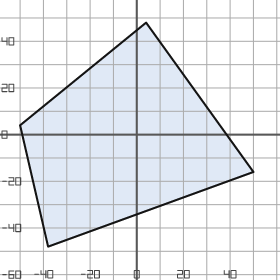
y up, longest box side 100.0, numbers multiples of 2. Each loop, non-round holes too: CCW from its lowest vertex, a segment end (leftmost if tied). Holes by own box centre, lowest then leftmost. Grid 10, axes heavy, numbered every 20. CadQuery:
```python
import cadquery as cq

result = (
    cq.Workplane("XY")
    .moveTo(-38.0, -48.0)
    .lineTo(50.0, -16.0)
    .lineTo(4.0, 48.0)
    .lineTo(-50.0, 4.0)
    .close()
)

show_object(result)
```